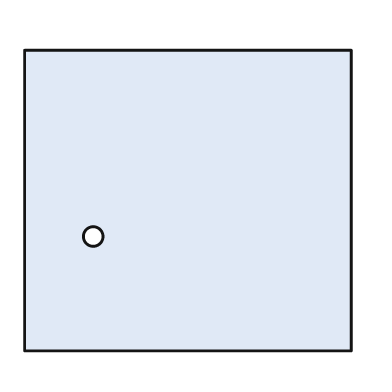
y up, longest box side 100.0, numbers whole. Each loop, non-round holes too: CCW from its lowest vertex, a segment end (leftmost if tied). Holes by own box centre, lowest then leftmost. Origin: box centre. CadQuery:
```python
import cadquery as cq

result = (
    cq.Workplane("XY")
    .moveTo(-50.0, -46.0)
    .lineTo(50.0, -46.0)
    .lineTo(50.0, 46.0)
    .lineTo(-50.0, 46.0)
    .close()
    .moveTo(-29.0, -11.0)
    .circle(3.0)
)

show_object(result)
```